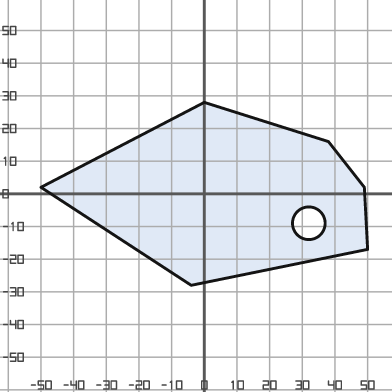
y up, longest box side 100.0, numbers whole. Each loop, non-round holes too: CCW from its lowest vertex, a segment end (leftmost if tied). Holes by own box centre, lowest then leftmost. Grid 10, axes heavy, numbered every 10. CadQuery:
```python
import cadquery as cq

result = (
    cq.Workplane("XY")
    .moveTo(-4.0, -28.0)
    .lineTo(50.0, -17.0)
    .lineTo(49.0, 2.0)
    .lineTo(38.0, 16.0)
    .lineTo(0.0, 28.0)
    .lineTo(-50.0, 2.0)
    .close()
    .moveTo(32.0, -9.0)
    .circle(5.0)
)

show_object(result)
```